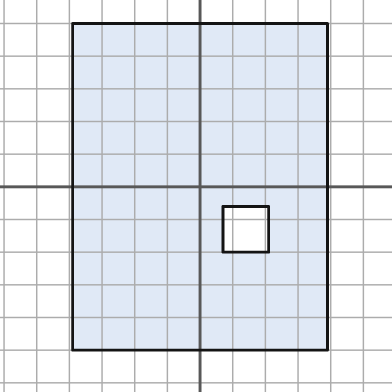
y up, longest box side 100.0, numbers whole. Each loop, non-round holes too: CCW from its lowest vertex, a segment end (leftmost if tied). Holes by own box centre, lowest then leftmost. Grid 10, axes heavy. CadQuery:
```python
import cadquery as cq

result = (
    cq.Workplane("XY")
    .moveTo(-39.0, -50.0)
    .lineTo(39.0, -50.0)
    .lineTo(39.0, 50.0)
    .lineTo(-39.0, 50.0)
    .close()
    .moveTo(7.0, -20.0)
    .lineTo(21.0, -20.0)
    .lineTo(21.0, -6.0)
    .lineTo(7.0, -6.0)
    .close()
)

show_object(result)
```